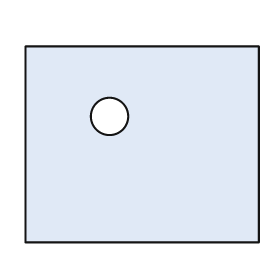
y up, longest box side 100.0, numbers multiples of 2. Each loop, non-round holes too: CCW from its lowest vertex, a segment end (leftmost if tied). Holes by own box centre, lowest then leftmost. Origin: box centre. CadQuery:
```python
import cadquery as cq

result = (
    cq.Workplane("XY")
    .moveTo(-50.0, -42.0)
    .lineTo(50.0, -42.0)
    .lineTo(50.0, 42.0)
    .lineTo(-50.0, 42.0)
    .close()
    .moveTo(-14.0, 12.0)
    .circle(8.0)
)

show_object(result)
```